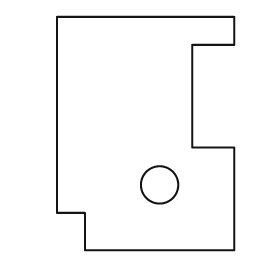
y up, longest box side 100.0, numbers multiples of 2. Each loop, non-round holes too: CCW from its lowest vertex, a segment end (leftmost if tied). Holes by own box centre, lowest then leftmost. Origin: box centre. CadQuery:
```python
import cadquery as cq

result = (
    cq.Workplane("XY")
    .moveTo(-26.0, -50.0)
    .lineTo(38.0, -50.0)
    .lineTo(38.0, -6.0)
    .lineTo(20.0, -6.0)
    .lineTo(20.0, 38.0)
    .lineTo(38.0, 38.0)
    .lineTo(38.0, 50.0)
    .lineTo(-38.0, 50.0)
    .lineTo(-38.0, -34.0)
    .lineTo(-26.0, -34.0)
    .close()
    .moveTo(6.0, -22.0)
    .circle(8.0)
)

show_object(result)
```